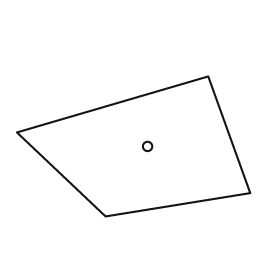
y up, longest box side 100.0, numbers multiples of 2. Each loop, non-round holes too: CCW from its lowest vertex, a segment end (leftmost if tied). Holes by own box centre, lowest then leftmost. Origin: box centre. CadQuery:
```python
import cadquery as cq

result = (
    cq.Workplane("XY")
    .moveTo(-12.0, -30.0)
    .lineTo(50.0, -20.0)
    .lineTo(32.0, 30.0)
    .lineTo(-50.0, 6.0)
    .close()
    .moveTo(6.0, 0.0)
    .circle(2.0)
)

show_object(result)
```